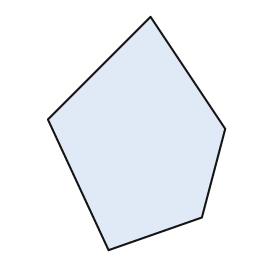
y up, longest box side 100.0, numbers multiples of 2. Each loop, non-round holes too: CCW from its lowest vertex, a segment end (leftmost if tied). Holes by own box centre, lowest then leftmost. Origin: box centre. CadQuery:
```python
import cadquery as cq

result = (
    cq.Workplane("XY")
    .moveTo(-12.0, -50.0)
    .lineTo(28.0, -36.0)
    .lineTo(38.0, 2.0)
    .lineTo(6.0, 50.0)
    .lineTo(-38.0, 6.0)
    .close()
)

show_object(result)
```